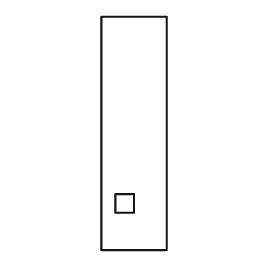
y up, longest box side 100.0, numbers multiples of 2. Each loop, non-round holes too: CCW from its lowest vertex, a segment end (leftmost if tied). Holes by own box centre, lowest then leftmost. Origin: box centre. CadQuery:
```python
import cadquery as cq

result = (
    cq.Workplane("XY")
    .moveTo(-14.0, -50.0)
    .lineTo(14.0, -50.0)
    .lineTo(14.0, 50.0)
    .lineTo(-14.0, 50.0)
    .close()
    .moveTo(-8.0, -34.0)
    .lineTo(0.0, -34.0)
    .lineTo(0.0, -26.0)
    .lineTo(-8.0, -26.0)
    .close()
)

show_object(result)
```